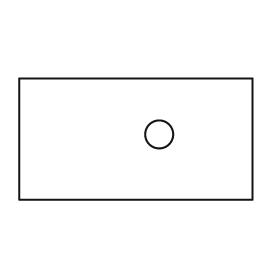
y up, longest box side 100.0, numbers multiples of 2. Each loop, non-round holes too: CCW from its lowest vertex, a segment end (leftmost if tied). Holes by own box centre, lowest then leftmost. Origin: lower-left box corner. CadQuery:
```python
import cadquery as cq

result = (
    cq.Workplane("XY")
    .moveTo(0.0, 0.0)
    .lineTo(100.0, 0.0)
    .lineTo(100.0, 52.0)
    .lineTo(0.0, 52.0)
    .close()
    .moveTo(60.0, 28.0)
    .circle(6.0)
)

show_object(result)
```